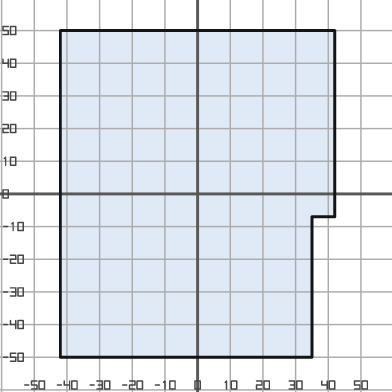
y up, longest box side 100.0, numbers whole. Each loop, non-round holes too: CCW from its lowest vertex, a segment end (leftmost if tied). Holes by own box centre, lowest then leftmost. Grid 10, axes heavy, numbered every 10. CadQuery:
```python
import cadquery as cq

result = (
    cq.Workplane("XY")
    .moveTo(-42.0, -50.0)
    .lineTo(35.0, -50.0)
    .lineTo(35.0, -7.0)
    .lineTo(42.0, -7.0)
    .lineTo(42.0, 50.0)
    .lineTo(-42.0, 50.0)
    .close()
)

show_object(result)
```